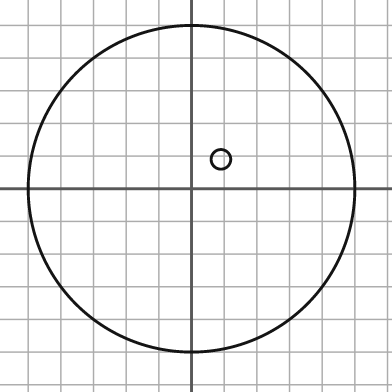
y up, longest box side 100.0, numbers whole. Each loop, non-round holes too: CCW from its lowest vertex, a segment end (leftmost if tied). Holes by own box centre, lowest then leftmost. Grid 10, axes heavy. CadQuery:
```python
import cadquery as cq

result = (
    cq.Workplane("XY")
    .moveTo(0.0, 0.0)
    .circle(50.0)
    .moveTo(9.0, 9.0)
    .circle(3.0)
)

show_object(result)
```